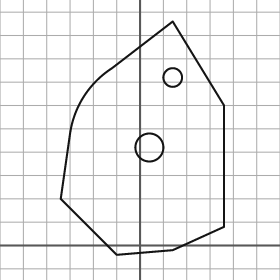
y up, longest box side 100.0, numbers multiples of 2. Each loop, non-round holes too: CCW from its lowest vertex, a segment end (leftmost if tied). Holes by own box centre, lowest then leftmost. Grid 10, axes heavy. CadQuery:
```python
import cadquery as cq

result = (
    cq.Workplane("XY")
    .moveTo(-10.0, -4.0)
    .lineTo(14.0, -2.0)
    .lineTo(36.0, 8.0)
    .lineTo(36.0, 60.0)
    .lineTo(14.0, 96.0)
    .lineTo(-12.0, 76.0)
    .threePointArc((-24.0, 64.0), (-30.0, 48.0))
    .lineTo(-34.0, 20.0)
    .close()
    .moveTo(4.0, 42.0)
    .circle(6.0)
    .moveTo(14.0, 72.0)
    .circle(4.0)
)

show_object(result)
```